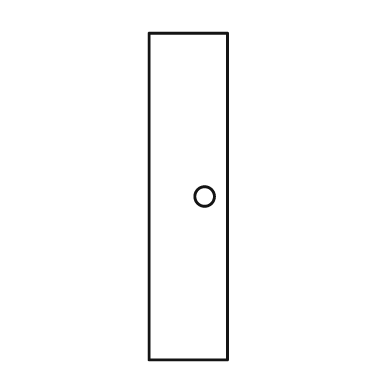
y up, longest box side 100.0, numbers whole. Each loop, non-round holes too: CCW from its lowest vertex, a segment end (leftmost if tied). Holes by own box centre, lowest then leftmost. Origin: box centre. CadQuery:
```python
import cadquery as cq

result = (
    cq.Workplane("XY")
    .moveTo(-12.0, -50.0)
    .lineTo(12.0, -50.0)
    .lineTo(12.0, 50.0)
    .lineTo(-12.0, 50.0)
    .close()
    .moveTo(5.0, 0.0)
    .circle(3.0)
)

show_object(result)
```